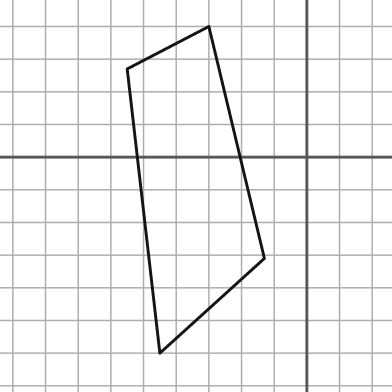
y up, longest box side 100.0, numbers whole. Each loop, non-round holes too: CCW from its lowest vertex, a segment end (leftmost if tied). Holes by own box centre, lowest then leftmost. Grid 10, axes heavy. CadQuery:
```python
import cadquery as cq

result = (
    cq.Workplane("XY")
    .moveTo(-45.0, -60.0)
    .lineTo(-13.0, -31.0)
    .lineTo(-30.0, 40.0)
    .lineTo(-55.0, 27.0)
    .close()
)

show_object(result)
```